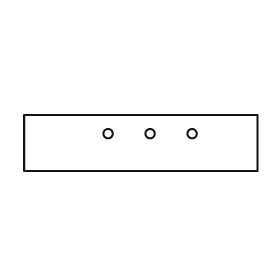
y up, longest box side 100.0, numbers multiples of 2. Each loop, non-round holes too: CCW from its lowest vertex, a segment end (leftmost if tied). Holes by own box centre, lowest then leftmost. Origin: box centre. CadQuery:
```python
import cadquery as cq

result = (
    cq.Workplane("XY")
    .moveTo(-50.0, -12.0)
    .lineTo(50.0, -12.0)
    .lineTo(50.0, 12.0)
    .lineTo(-50.0, 12.0)
    .close()
    .moveTo(-14.0, 4.0)
    .circle(2.0)
    .moveTo(4.0, 4.0)
    .circle(2.0)
    .moveTo(22.0, 4.0)
    .circle(2.0)
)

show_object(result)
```